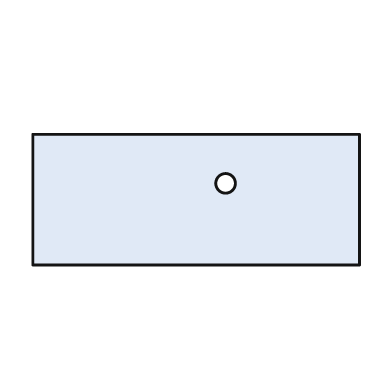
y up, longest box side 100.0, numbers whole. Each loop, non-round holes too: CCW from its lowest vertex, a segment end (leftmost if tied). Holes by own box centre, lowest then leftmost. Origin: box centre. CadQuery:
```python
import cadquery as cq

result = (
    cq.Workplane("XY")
    .moveTo(-50.0, -20.0)
    .lineTo(50.0, -20.0)
    .lineTo(50.0, 20.0)
    .lineTo(-50.0, 20.0)
    .close()
    .moveTo(9.0, 5.0)
    .circle(3.0)
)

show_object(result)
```